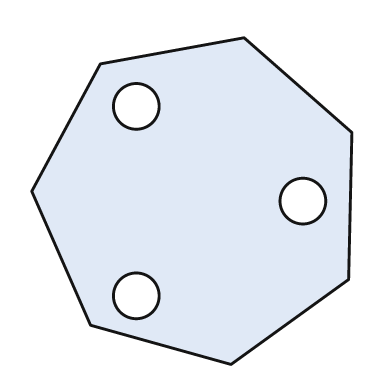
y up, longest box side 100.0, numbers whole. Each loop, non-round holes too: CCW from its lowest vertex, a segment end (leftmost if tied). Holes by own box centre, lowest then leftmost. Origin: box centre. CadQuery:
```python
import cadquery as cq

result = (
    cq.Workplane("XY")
    .moveTo(12.0, -50.0)
    .lineTo(48.0, -24.0)
    .lineTo(49.0, 21.0)
    .lineTo(16.0, 50.0)
    .lineTo(-28.0, 42.0)
    .lineTo(-49.0, 3.0)
    .lineTo(-31.0, -38.0)
    .close()
    .moveTo(-17.0, -29.0)
    .circle(7.0)
    .moveTo(34.0, 0.0)
    .circle(7.0)
    .moveTo(-17.0, 29.0)
    .circle(7.0)
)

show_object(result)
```